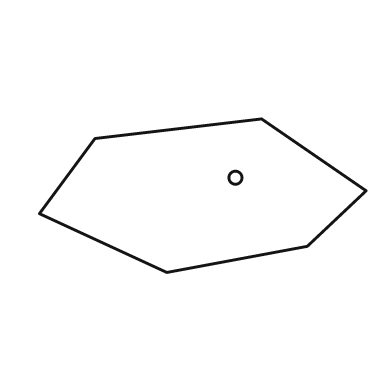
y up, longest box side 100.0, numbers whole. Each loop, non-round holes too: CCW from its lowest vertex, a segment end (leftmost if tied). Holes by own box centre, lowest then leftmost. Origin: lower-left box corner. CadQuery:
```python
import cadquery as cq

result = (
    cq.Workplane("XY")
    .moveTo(39.0, 0.0)
    .lineTo(82.0, 8.0)
    .lineTo(100.0, 25.0)
    .lineTo(68.0, 47.0)
    .lineTo(17.0, 41.0)
    .lineTo(0.0, 18.0)
    .close()
    .moveTo(60.0, 29.0)
    .circle(2.0)
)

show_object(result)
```